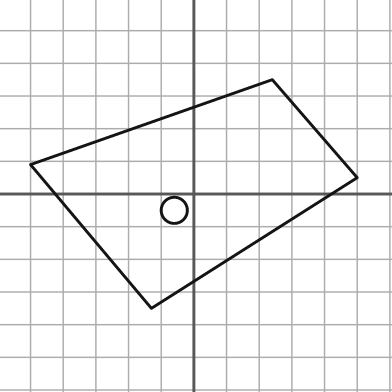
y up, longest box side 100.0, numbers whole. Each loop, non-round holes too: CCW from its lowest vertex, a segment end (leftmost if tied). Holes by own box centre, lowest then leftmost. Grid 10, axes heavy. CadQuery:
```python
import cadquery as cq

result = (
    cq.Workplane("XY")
    .moveTo(-13.0, -35.0)
    .lineTo(50.0, 5.0)
    .lineTo(24.0, 35.0)
    .lineTo(-50.0, 9.0)
    .close()
    .moveTo(-6.0, -5.0)
    .circle(4.0)
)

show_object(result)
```